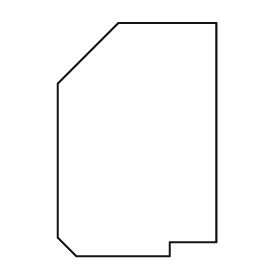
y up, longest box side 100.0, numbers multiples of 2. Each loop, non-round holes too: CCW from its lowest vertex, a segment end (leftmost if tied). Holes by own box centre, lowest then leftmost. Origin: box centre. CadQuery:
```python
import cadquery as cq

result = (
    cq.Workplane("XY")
    .moveTo(-26.0, -50.0)
    .lineTo(14.0, -50.0)
    .lineTo(14.0, -44.0)
    .lineTo(34.0, -44.0)
    .lineTo(34.0, 50.0)
    .lineTo(-8.0, 50.0)
    .lineTo(-34.0, 24.0)
    .lineTo(-34.0, -42.0)
    .close()
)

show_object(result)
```